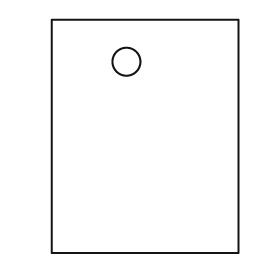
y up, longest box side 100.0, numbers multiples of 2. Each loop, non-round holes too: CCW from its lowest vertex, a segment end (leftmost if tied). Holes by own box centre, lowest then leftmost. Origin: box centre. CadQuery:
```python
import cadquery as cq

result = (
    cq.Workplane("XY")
    .moveTo(-40.0, -50.0)
    .lineTo(40.0, -50.0)
    .lineTo(40.0, 50.0)
    .lineTo(-40.0, 50.0)
    .close()
    .moveTo(-8.0, 32.0)
    .circle(6.0)
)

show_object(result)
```